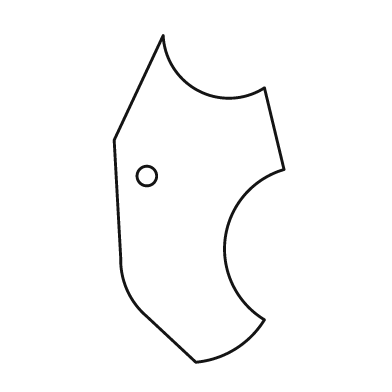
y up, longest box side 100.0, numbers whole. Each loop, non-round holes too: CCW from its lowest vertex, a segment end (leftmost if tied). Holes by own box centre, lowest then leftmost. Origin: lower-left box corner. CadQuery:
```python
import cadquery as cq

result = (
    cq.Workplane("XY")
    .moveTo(25.0, 0.0)
    .threePointArc((37.0, 4.0), (46.0, 13.0))
    .threePointArc((34.0, 38.0), (52.0, 59.0))
    .lineTo(46.0, 84.0)
    .threePointArc((26.0, 83.0), (15.0, 100.0))
    .lineTo(0.0, 68.0)
    .lineTo(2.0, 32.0)
    .threePointArc((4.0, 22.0), (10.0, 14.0))
    .close()
    .moveTo(10.0, 57.0)
    .circle(3.0)
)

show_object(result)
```